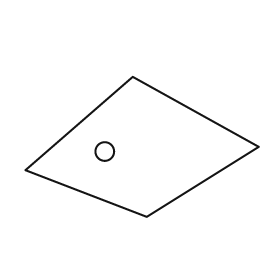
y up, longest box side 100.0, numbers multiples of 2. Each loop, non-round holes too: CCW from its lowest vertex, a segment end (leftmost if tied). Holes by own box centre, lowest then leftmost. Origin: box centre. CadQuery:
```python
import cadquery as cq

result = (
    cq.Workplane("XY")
    .moveTo(2.0, -30.0)
    .lineTo(50.0, 0.0)
    .lineTo(-4.0, 30.0)
    .lineTo(-50.0, -10.0)
    .close()
    .moveTo(-16.0, -2.0)
    .circle(4.0)
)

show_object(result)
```